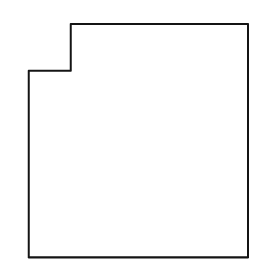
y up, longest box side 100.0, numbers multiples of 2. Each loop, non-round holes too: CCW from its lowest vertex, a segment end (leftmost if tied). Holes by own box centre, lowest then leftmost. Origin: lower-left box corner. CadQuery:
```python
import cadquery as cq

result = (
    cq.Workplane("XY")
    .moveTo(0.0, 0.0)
    .lineTo(94.0, 0.0)
    .lineTo(94.0, 100.0)
    .lineTo(18.0, 100.0)
    .lineTo(18.0, 80.0)
    .lineTo(0.0, 80.0)
    .close()
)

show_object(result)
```